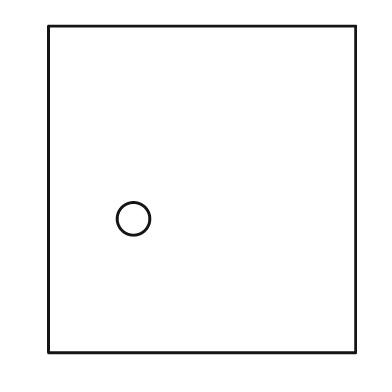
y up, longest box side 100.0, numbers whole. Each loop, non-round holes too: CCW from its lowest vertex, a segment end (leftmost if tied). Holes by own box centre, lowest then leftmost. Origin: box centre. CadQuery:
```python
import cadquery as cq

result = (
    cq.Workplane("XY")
    .moveTo(-47.0, -50.0)
    .lineTo(47.0, -50.0)
    .lineTo(47.0, 50.0)
    .lineTo(-47.0, 50.0)
    .close()
    .moveTo(-21.0, -9.0)
    .circle(5.0)
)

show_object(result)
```